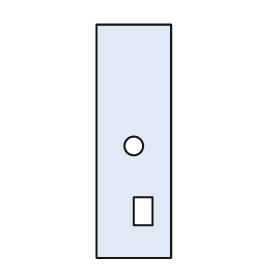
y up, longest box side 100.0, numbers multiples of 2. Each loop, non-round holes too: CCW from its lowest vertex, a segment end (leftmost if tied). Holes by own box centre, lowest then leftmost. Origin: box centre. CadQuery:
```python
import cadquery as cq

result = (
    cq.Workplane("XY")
    .moveTo(-16.0, -50.0)
    .lineTo(16.0, -50.0)
    .lineTo(16.0, 50.0)
    .lineTo(-16.0, 50.0)
    .close()
    .moveTo(0.0, -36.0)
    .lineTo(8.0, -36.0)
    .lineTo(8.0, -24.0)
    .lineTo(0.0, -24.0)
    .close()
    .moveTo(0.0, -2.0)
    .circle(4.0)
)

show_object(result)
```